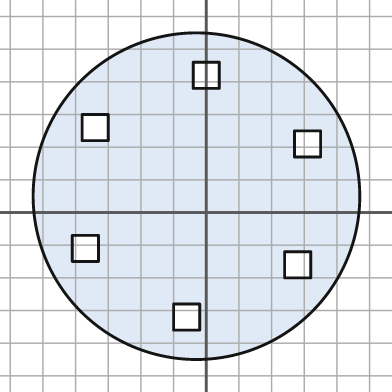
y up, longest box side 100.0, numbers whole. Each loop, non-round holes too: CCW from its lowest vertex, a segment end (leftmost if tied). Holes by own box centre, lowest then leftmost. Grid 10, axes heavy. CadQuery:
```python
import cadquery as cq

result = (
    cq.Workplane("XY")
    .moveTo(-3.0, 5.0)
    .circle(50.0)
    .moveTo(-10.0, -36.0)
    .lineTo(-2.0, -36.0)
    .lineTo(-2.0, -28.0)
    .lineTo(-10.0, -28.0)
    .close()
    .moveTo(24.0, -20.0)
    .lineTo(32.0, -20.0)
    .lineTo(32.0, -12.0)
    .lineTo(24.0, -12.0)
    .close()
    .moveTo(-41.0, -15.0)
    .lineTo(-33.0, -15.0)
    .lineTo(-33.0, -7.0)
    .lineTo(-41.0, -7.0)
    .close()
    .moveTo(27.0, 17.0)
    .lineTo(35.0, 17.0)
    .lineTo(35.0, 25.0)
    .lineTo(27.0, 25.0)
    .close()
    .moveTo(-38.0, 22.0)
    .lineTo(-30.0, 22.0)
    .lineTo(-30.0, 30.0)
    .lineTo(-38.0, 30.0)
    .close()
    .moveTo(-4.0, 38.0)
    .lineTo(4.0, 38.0)
    .lineTo(4.0, 46.0)
    .lineTo(-4.0, 46.0)
    .close()
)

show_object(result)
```